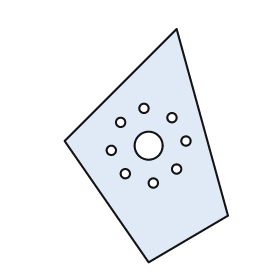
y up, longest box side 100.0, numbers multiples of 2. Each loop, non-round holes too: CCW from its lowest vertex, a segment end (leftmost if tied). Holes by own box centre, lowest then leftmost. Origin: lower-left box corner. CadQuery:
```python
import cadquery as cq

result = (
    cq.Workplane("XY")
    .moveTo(36.0, 0.0)
    .lineTo(70.0, 20.0)
    .lineTo(48.0, 100.0)
    .lineTo(0.0, 52.0)
    .close()
    .moveTo(38.0, 34.0)
    .circle(2.0)
    .moveTo(26.0, 38.0)
    .circle(2.0)
    .moveTo(48.0, 40.0)
    .circle(2.0)
    .moveTo(20.0, 48.0)
    .circle(2.0)
    .moveTo(36.0, 50.0)
    .circle(6.0)
    .moveTo(52.0, 52.0)
    .circle(2.0)
    .moveTo(24.0, 60.0)
    .circle(2.0)
    .moveTo(46.0, 62.0)
    .circle(2.0)
    .moveTo(34.0, 66.0)
    .circle(2.0)
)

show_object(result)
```